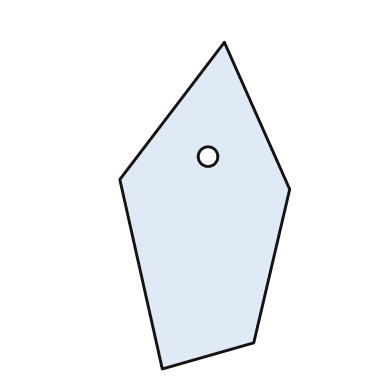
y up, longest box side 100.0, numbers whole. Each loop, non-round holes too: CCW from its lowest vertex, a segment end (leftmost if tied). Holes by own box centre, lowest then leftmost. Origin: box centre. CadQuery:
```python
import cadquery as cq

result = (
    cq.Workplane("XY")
    .moveTo(-13.0, -50.0)
    .lineTo(15.0, -42.0)
    .lineTo(26.0, 5.0)
    .lineTo(6.0, 50.0)
    .lineTo(-26.0, 8.0)
    .close()
    .moveTo(1.0, 15.0)
    .circle(3.0)
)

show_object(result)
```